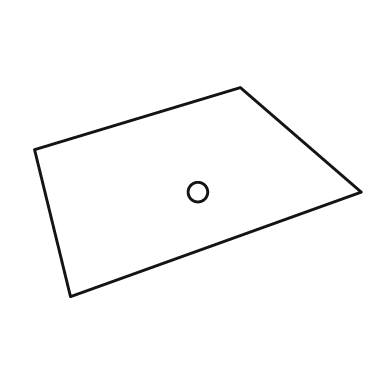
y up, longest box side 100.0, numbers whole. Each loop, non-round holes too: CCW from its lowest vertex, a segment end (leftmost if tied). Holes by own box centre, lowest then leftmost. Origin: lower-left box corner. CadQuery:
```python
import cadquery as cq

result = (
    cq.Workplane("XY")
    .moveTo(11.0, 0.0)
    .lineTo(100.0, 32.0)
    .lineTo(63.0, 64.0)
    .lineTo(0.0, 45.0)
    .close()
    .moveTo(50.0, 32.0)
    .circle(3.0)
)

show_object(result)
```